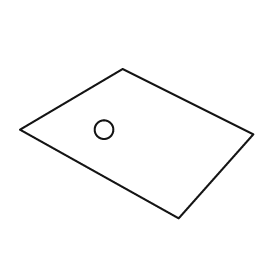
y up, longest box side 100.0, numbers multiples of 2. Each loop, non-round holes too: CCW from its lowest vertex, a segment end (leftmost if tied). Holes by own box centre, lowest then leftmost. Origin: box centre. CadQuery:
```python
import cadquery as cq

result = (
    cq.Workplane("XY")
    .moveTo(18.0, -32.0)
    .lineTo(50.0, 4.0)
    .lineTo(-6.0, 32.0)
    .lineTo(-50.0, 6.0)
    .close()
    .moveTo(-14.0, 6.0)
    .circle(4.0)
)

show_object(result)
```